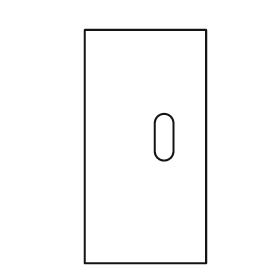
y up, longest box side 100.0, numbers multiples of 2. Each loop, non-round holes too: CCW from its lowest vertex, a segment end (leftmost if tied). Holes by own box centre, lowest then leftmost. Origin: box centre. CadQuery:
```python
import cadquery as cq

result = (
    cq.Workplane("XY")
    .moveTo(-26.0, -50.0)
    .lineTo(26.0, -50.0)
    .lineTo(26.0, 50.0)
    .lineTo(-26.0, 50.0)
    .close()
    .moveTo(4.0, -2.0)
    .threePointArc((8.0, -6.0), (12.0, -2.0))
    .lineTo(12.0, 10.0)
    .threePointArc((8.0, 14.0), (4.0, 10.0))
    .close()
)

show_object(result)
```